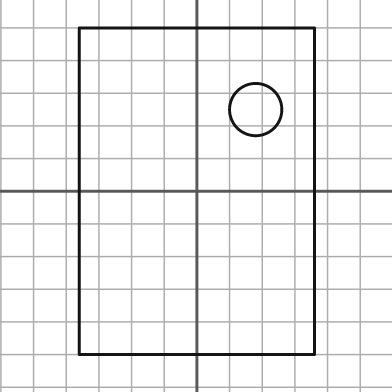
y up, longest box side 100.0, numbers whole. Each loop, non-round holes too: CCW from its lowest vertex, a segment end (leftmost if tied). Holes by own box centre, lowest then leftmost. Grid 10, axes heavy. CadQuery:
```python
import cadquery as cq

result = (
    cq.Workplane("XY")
    .moveTo(-36.0, -50.0)
    .lineTo(36.0, -50.0)
    .lineTo(36.0, 50.0)
    .lineTo(-36.0, 50.0)
    .close()
    .moveTo(18.0, 25.0)
    .circle(8.0)
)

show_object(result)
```